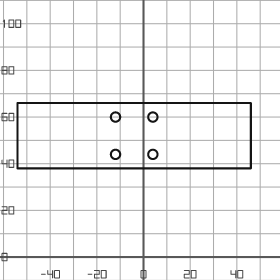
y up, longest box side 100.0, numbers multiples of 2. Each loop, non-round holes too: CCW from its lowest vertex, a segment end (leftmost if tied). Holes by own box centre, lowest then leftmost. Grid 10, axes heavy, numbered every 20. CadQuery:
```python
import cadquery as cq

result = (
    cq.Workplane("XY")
    .moveTo(-54.0, 38.0)
    .lineTo(46.0, 38.0)
    .lineTo(46.0, 66.0)
    .lineTo(-54.0, 66.0)
    .close()
    .moveTo(-12.0, 44.0)
    .circle(2.0)
    .moveTo(4.0, 44.0)
    .circle(2.0)
    .moveTo(-12.0, 60.0)
    .circle(2.0)
    .moveTo(4.0, 60.0)
    .circle(2.0)
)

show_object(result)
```